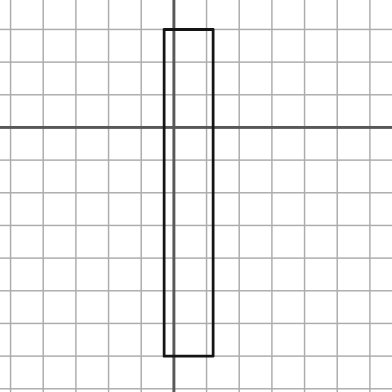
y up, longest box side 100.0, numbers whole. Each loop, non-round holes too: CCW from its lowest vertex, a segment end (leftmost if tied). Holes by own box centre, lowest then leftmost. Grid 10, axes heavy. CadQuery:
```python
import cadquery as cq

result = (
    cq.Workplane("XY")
    .moveTo(-3.0, -70.0)
    .lineTo(12.0, -70.0)
    .lineTo(12.0, 30.0)
    .lineTo(-3.0, 30.0)
    .close()
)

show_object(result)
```